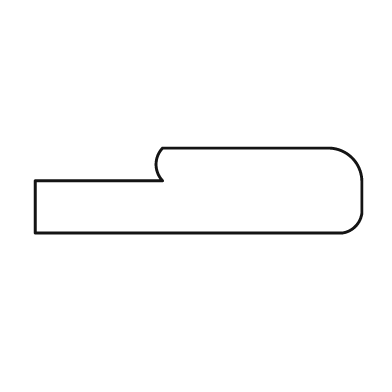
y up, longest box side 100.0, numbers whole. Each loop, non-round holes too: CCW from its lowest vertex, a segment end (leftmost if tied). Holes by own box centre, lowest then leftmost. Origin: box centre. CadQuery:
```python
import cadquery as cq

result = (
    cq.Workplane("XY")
    .moveTo(-50.0, -13.0)
    .lineTo(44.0, -13.0)
    .threePointArc((48.0, -11.0), (50.0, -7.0))
    .lineTo(50.0, 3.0)
    .threePointArc((47.0, 10.0), (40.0, 13.0))
    .lineTo(-11.0, 13.0)
    .threePointArc((-13.0, 8.0), (-11.0, 3.0))
    .lineTo(-50.0, 3.0)
    .close()
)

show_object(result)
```